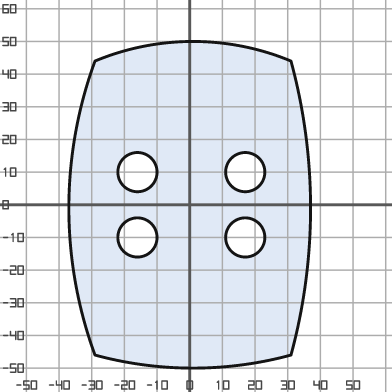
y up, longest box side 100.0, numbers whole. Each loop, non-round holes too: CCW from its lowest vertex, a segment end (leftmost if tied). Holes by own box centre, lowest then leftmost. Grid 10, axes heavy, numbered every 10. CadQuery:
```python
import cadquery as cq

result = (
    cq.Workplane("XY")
    .moveTo(-29.0, -46.0)
    .threePointArc((1.0, -50.0), (31.0, -46.0))
    .threePointArc((37.0, -1.0), (31.0, 44.0))
    .threePointArc((1.0, 50.0), (-29.0, 44.0))
    .threePointArc((-37.0, -1.0), (-29.0, -46.0))
    .close()
    .moveTo(-16.0, -10.0)
    .circle(6.0)
    .moveTo(17.0, -10.0)
    .circle(6.0)
    .moveTo(-16.0, 10.0)
    .circle(6.0)
    .moveTo(17.0, 10.0)
    .circle(6.0)
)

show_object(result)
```